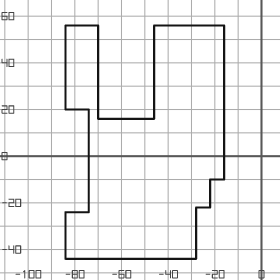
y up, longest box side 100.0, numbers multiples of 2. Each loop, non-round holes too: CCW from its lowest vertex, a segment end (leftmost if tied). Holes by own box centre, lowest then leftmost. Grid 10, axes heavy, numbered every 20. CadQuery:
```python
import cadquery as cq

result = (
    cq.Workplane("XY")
    .moveTo(-84.0, -44.0)
    .lineTo(-28.0, -44.0)
    .lineTo(-28.0, -22.0)
    .lineTo(-22.0, -22.0)
    .lineTo(-22.0, -10.0)
    .lineTo(-16.0, -10.0)
    .lineTo(-16.0, 56.0)
    .lineTo(-46.0, 56.0)
    .lineTo(-46.0, 16.0)
    .lineTo(-70.0, 16.0)
    .lineTo(-70.0, 56.0)
    .lineTo(-84.0, 56.0)
    .lineTo(-84.0, 20.0)
    .lineTo(-74.0, 20.0)
    .lineTo(-74.0, -24.0)
    .lineTo(-84.0, -24.0)
    .close()
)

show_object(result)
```